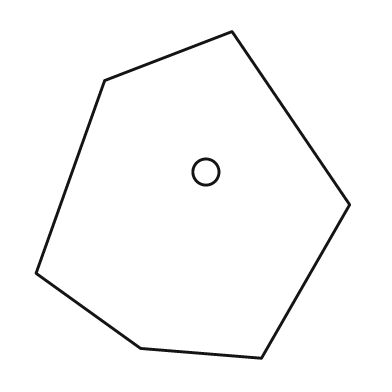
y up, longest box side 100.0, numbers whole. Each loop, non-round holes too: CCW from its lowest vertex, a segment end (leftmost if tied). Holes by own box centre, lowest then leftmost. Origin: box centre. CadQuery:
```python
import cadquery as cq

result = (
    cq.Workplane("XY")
    .moveTo(21.0, -50.0)
    .lineTo(48.0, -3.0)
    .lineTo(12.0, 50.0)
    .lineTo(-27.0, 35.0)
    .lineTo(-48.0, -24.0)
    .lineTo(-16.0, -47.0)
    .close()
    .moveTo(4.0, 7.0)
    .circle(4.0)
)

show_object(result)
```